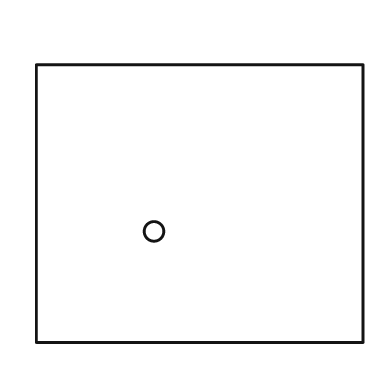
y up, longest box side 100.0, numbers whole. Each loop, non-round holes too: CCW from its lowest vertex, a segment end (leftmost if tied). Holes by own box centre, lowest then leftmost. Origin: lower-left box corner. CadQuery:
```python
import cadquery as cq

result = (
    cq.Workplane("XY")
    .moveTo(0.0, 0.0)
    .lineTo(100.0, 0.0)
    .lineTo(100.0, 85.0)
    .lineTo(0.0, 85.0)
    .close()
    .moveTo(36.0, 34.0)
    .circle(3.0)
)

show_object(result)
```